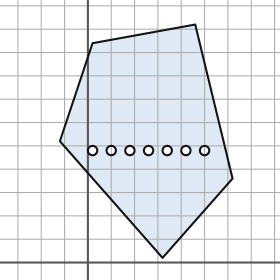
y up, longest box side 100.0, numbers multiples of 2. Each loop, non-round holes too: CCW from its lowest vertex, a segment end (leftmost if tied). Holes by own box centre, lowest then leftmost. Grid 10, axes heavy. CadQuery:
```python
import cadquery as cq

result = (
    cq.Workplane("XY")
    .moveTo(32.0, 2.0)
    .lineTo(62.0, 36.0)
    .lineTo(46.0, 102.0)
    .lineTo(2.0, 94.0)
    .lineTo(-12.0, 52.0)
    .close()
    .moveTo(2.0, 48.0)
    .circle(2.0)
    .moveTo(10.0, 48.0)
    .circle(2.0)
    .moveTo(18.0, 48.0)
    .circle(2.0)
    .moveTo(26.0, 48.0)
    .circle(2.0)
    .moveTo(34.0, 48.0)
    .circle(2.0)
    .moveTo(42.0, 48.0)
    .circle(2.0)
    .moveTo(50.0, 48.0)
    .circle(2.0)
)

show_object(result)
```